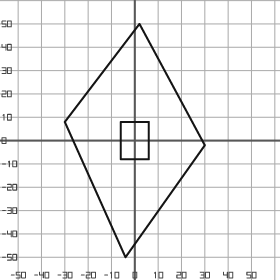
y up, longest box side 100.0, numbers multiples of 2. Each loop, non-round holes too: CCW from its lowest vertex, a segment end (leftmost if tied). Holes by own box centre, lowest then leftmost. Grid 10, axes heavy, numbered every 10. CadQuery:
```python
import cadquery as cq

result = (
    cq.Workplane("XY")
    .moveTo(-4.0, -50.0)
    .lineTo(30.0, -2.0)
    .lineTo(2.0, 50.0)
    .lineTo(-30.0, 8.0)
    .close()
    .moveTo(-6.0, -8.0)
    .lineTo(6.0, -8.0)
    .lineTo(6.0, 8.0)
    .lineTo(-6.0, 8.0)
    .close()
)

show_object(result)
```